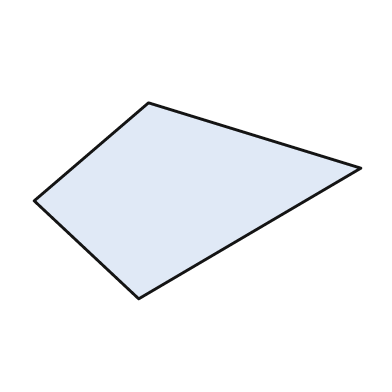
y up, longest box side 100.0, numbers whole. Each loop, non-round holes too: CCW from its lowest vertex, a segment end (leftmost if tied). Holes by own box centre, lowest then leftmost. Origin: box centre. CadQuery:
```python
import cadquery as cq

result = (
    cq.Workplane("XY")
    .moveTo(-18.0, -30.0)
    .lineTo(50.0, 10.0)
    .lineTo(-15.0, 30.0)
    .lineTo(-50.0, 0.0)
    .close()
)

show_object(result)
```